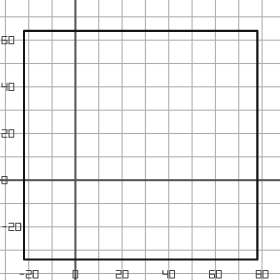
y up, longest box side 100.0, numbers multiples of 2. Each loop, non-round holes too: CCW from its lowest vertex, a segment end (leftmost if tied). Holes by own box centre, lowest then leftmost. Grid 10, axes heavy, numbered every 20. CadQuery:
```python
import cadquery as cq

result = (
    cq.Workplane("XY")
    .moveTo(-22.0, -34.0)
    .lineTo(78.0, -34.0)
    .lineTo(78.0, 64.0)
    .lineTo(-22.0, 64.0)
    .close()
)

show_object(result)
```